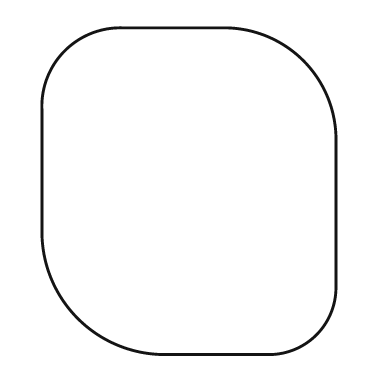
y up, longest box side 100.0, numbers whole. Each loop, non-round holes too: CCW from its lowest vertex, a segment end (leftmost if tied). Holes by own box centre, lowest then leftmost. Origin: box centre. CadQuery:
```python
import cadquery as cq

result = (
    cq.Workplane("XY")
    .moveTo(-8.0, -50.0)
    .lineTo(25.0, -50.0)
    .threePointArc((39.0, -44.0), (45.0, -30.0))
    .lineTo(45.0, 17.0)
    .threePointArc((35.0, 40.0), (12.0, 50.0))
    .lineTo(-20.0, 50.0)
    .threePointArc((-38.0, 43.0), (-45.0, 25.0))
    .lineTo(-45.0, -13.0)
    .threePointArc((-34.0, -39.0), (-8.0, -50.0))
    .close()
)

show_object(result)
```